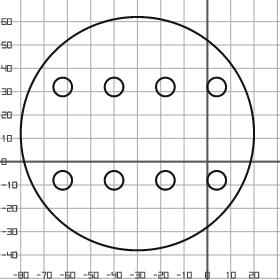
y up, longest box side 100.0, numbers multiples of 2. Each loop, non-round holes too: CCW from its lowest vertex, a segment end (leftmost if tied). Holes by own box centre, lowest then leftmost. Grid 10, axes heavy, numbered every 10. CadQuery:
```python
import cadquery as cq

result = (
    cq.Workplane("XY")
    .moveTo(-30.0, 12.0)
    .circle(50.0)
    .moveTo(-62.0, -8.0)
    .circle(4.0)
    .moveTo(-40.0, -8.0)
    .circle(4.0)
    .moveTo(-18.0, -8.0)
    .circle(4.0)
    .moveTo(4.0, -8.0)
    .circle(4.0)
    .moveTo(-62.0, 32.0)
    .circle(4.0)
    .moveTo(-40.0, 32.0)
    .circle(4.0)
    .moveTo(-18.0, 32.0)
    .circle(4.0)
    .moveTo(4.0, 32.0)
    .circle(4.0)
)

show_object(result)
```